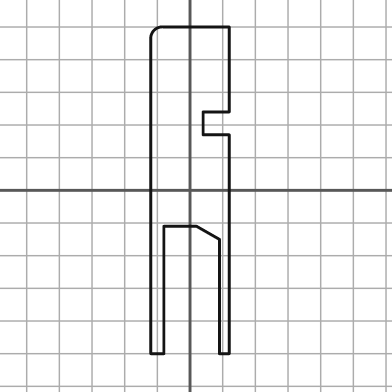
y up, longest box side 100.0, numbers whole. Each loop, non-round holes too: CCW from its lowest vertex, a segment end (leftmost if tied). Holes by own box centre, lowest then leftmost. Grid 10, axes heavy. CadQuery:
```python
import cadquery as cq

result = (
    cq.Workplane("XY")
    .moveTo(-12.0, -50.0)
    .lineTo(-8.0, -50.0)
    .lineTo(-8.0, -11.0)
    .lineTo(2.0, -11.0)
    .lineTo(9.0, -15.0)
    .lineTo(9.0, -50.0)
    .lineTo(12.0, -50.0)
    .lineTo(12.0, 17.0)
    .lineTo(4.0, 17.0)
    .lineTo(4.0, 24.0)
    .lineTo(12.0, 24.0)
    .lineTo(12.0, 50.0)
    .lineTo(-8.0, 50.0)
    .threePointArc((-11.0, 49.0), (-12.0, 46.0))
    .close()
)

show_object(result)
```